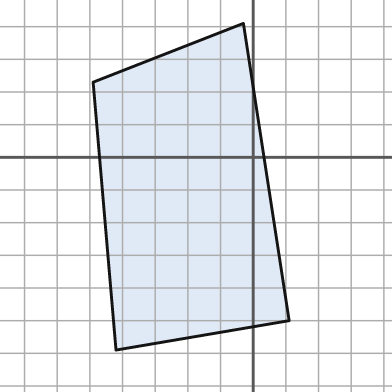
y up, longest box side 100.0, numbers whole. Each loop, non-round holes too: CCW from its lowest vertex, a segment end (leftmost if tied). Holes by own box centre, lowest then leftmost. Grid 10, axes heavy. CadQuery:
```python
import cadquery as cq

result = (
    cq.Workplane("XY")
    .moveTo(-42.0, -59.0)
    .lineTo(11.0, -50.0)
    .lineTo(-3.0, 41.0)
    .lineTo(-49.0, 23.0)
    .close()
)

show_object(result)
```